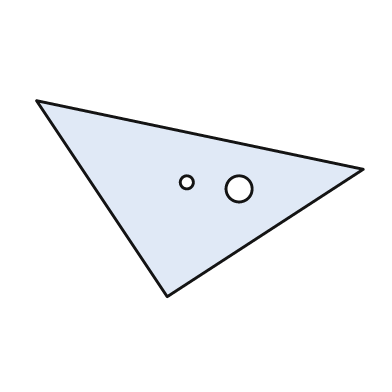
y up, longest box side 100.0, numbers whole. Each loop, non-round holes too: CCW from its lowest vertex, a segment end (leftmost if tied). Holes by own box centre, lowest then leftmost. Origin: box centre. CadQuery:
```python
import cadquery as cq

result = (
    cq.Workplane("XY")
    .moveTo(-10.0, -30.0)
    .lineTo(50.0, 9.0)
    .lineTo(-50.0, 30.0)
    .close()
    .moveTo(12.0, 3.0)
    .circle(4.0)
    .moveTo(-4.0, 5.0)
    .circle(2.0)
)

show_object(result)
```